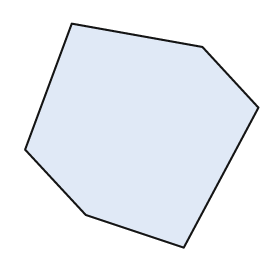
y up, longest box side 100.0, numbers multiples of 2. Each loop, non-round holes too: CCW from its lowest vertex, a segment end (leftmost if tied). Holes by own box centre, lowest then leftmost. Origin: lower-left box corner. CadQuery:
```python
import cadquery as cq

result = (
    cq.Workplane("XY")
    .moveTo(68.0, 0.0)
    .lineTo(100.0, 60.0)
    .lineTo(76.0, 86.0)
    .lineTo(20.0, 96.0)
    .lineTo(0.0, 42.0)
    .lineTo(26.0, 14.0)
    .close()
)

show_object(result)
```